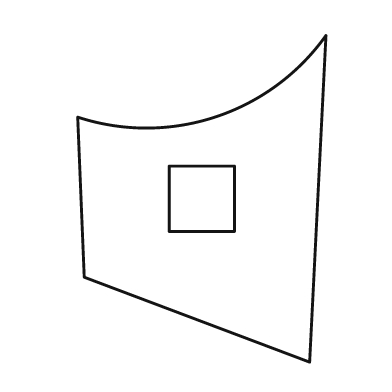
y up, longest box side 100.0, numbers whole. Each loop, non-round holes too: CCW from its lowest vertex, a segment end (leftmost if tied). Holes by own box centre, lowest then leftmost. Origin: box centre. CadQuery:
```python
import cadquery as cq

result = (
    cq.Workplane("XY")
    .moveTo(33.0, -50.0)
    .lineTo(38.0, 50.0)
    .threePointArc((4.0, 25.0), (-38.0, 25.0))
    .lineTo(-36.0, -24.0)
    .close()
    .moveTo(-10.0, -10.0)
    .lineTo(10.0, -10.0)
    .lineTo(10.0, 10.0)
    .lineTo(-10.0, 10.0)
    .close()
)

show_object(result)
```